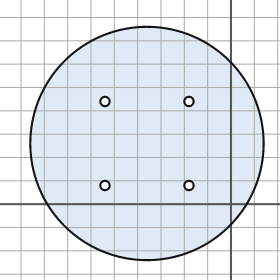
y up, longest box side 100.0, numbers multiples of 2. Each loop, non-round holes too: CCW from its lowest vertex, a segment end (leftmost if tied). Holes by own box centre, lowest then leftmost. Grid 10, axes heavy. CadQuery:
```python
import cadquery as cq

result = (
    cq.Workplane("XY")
    .moveTo(-36.0, 26.0)
    .circle(50.0)
    .moveTo(-54.0, 8.0)
    .circle(2.0)
    .moveTo(-18.0, 8.0)
    .circle(2.0)
    .moveTo(-54.0, 44.0)
    .circle(2.0)
    .moveTo(-18.0, 44.0)
    .circle(2.0)
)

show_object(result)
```